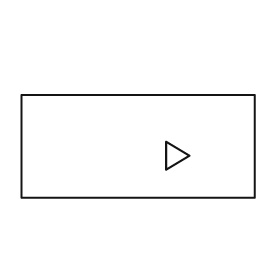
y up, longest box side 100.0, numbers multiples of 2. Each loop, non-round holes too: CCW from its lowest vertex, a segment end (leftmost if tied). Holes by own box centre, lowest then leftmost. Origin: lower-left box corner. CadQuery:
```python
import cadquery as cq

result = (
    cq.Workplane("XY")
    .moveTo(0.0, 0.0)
    .lineTo(100.0, 0.0)
    .lineTo(100.0, 44.0)
    .lineTo(0.0, 44.0)
    .close()
    .moveTo(62.0, 12.0)
    .lineTo(72.0, 18.0)
    .lineTo(62.0, 24.0)
    .close()
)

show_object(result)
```